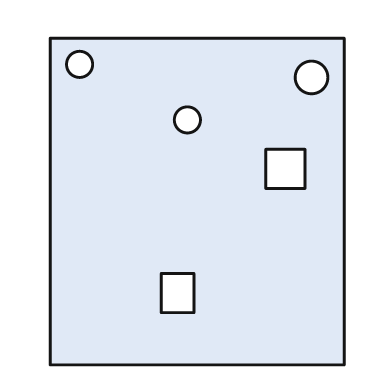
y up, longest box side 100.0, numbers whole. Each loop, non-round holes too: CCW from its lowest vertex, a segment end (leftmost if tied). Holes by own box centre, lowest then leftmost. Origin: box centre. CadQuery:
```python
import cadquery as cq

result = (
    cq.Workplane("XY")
    .moveTo(-45.0, -50.0)
    .lineTo(45.0, -50.0)
    .lineTo(45.0, 50.0)
    .lineTo(-45.0, 50.0)
    .close()
    .moveTo(-11.0, -34.0)
    .lineTo(-1.0, -34.0)
    .lineTo(-1.0, -22.0)
    .lineTo(-11.0, -22.0)
    .close()
    .moveTo(21.0, 4.0)
    .lineTo(33.0, 4.0)
    .lineTo(33.0, 16.0)
    .lineTo(21.0, 16.0)
    .close()
    .moveTo(-3.0, 25.0)
    .circle(4.0)
    .moveTo(35.0, 38.0)
    .circle(5.0)
    .moveTo(-36.0, 42.0)
    .circle(4.0)
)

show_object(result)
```